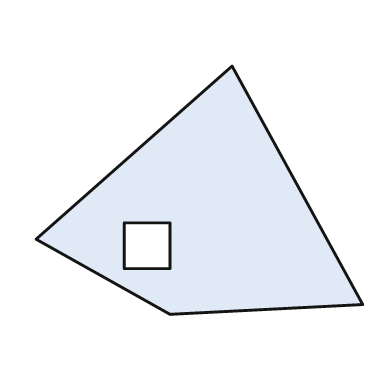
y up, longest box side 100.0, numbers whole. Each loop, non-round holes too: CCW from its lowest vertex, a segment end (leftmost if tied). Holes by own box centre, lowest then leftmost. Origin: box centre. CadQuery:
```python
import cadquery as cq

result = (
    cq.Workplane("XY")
    .moveTo(-9.0, -38.0)
    .lineTo(50.0, -35.0)
    .lineTo(10.0, 38.0)
    .lineTo(-50.0, -15.0)
    .close()
    .moveTo(-23.0, -24.0)
    .lineTo(-9.0, -24.0)
    .lineTo(-9.0, -10.0)
    .lineTo(-23.0, -10.0)
    .close()
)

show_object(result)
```